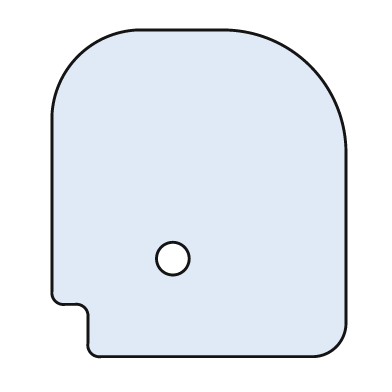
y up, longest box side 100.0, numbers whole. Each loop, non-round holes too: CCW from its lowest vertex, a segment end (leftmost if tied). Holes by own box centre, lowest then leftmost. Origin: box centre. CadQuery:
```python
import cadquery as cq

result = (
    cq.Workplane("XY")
    .moveTo(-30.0, -50.0)
    .lineTo(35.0, -50.0)
    .threePointArc((42.0, -47.0), (45.0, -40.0))
    .lineTo(45.0, 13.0)
    .threePointArc((34.0, 39.0), (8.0, 50.0))
    .lineTo(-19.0, 50.0)
    .threePointArc((-37.0, 42.0), (-45.0, 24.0))
    .lineTo(-45.0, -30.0)
    .threePointArc((-44.0, -33.0), (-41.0, -34.0))
    .lineTo(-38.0, -34.0)
    .threePointArc((-35.0, -35.0), (-34.0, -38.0))
    .lineTo(-34.0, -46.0)
    .threePointArc((-33.0, -49.0), (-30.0, -50.0))
    .close()
    .moveTo(-8.0, -20.0)
    .circle(5.0)
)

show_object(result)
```